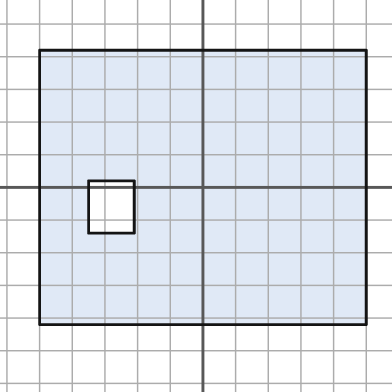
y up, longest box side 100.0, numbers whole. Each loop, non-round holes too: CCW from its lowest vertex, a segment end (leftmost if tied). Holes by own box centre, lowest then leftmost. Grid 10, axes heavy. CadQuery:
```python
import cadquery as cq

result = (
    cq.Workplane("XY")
    .moveTo(-50.0, -42.0)
    .lineTo(50.0, -42.0)
    .lineTo(50.0, 42.0)
    .lineTo(-50.0, 42.0)
    .close()
    .moveTo(-35.0, -14.0)
    .lineTo(-21.0, -14.0)
    .lineTo(-21.0, 2.0)
    .lineTo(-35.0, 2.0)
    .close()
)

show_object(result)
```